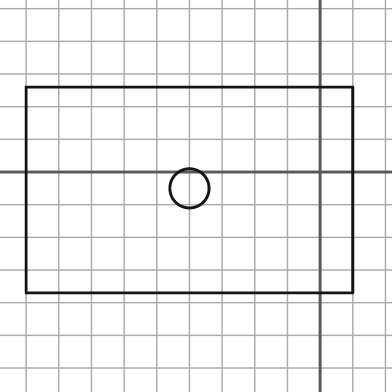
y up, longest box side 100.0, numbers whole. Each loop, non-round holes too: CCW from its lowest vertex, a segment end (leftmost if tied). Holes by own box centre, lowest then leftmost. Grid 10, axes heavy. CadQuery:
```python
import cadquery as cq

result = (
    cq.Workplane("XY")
    .moveTo(-90.0, -37.0)
    .lineTo(10.0, -37.0)
    .lineTo(10.0, 26.0)
    .lineTo(-90.0, 26.0)
    .close()
    .moveTo(-40.0, -5.0)
    .circle(6.0)
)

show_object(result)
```